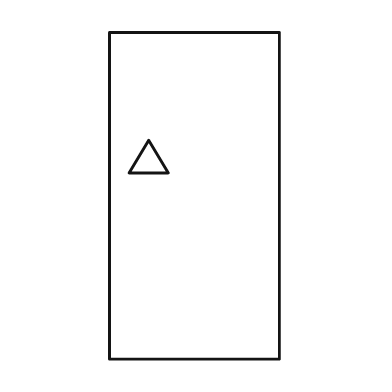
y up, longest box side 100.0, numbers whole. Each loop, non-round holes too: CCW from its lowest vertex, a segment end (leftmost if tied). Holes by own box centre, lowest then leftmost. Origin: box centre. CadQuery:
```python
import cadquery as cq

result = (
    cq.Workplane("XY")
    .moveTo(-26.0, -50.0)
    .lineTo(26.0, -50.0)
    .lineTo(26.0, 50.0)
    .lineTo(-26.0, 50.0)
    .close()
    .moveTo(-20.0, 7.0)
    .lineTo(-8.0, 7.0)
    .lineTo(-14.0, 17.0)
    .close()
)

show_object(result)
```